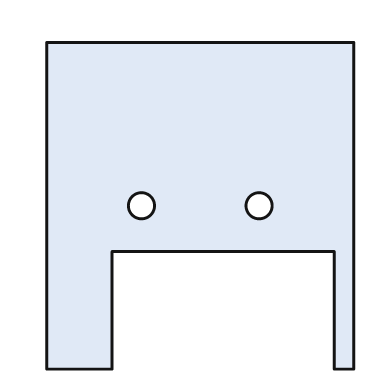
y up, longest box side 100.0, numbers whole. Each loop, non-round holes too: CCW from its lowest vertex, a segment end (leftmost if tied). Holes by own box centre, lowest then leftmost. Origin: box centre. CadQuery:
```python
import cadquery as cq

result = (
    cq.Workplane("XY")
    .moveTo(-47.0, -50.0)
    .lineTo(-27.0, -50.0)
    .lineTo(-27.0, -14.0)
    .lineTo(41.0, -14.0)
    .lineTo(41.0, -50.0)
    .lineTo(47.0, -50.0)
    .lineTo(47.0, 50.0)
    .lineTo(-47.0, 50.0)
    .close()
    .moveTo(-18.0, 0.0)
    .circle(4.0)
    .moveTo(18.0, 0.0)
    .circle(4.0)
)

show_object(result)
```